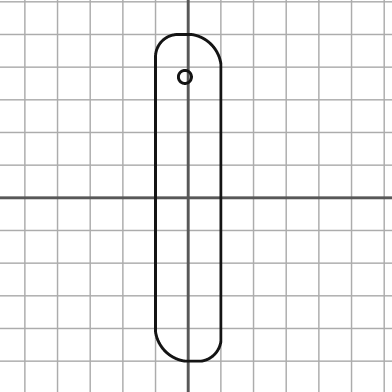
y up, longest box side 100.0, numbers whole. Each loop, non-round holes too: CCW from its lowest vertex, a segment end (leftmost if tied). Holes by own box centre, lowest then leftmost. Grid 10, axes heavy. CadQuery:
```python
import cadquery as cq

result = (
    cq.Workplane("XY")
    .moveTo(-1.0, -50.0)
    .lineTo(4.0, -50.0)
    .threePointArc((8.0, -48.0), (10.0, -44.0))
    .lineTo(10.0, 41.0)
    .threePointArc((7.0, 47.0), (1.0, 50.0))
    .lineTo(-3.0, 50.0)
    .threePointArc((-8.0, 48.0), (-10.0, 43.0))
    .lineTo(-10.0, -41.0)
    .threePointArc((-7.0, -47.0), (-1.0, -50.0))
    .close()
    .moveTo(-1.0, 37.0)
    .circle(2.0)
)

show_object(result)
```